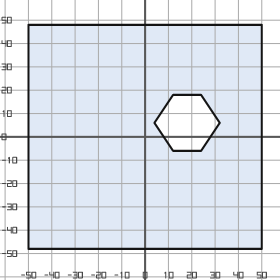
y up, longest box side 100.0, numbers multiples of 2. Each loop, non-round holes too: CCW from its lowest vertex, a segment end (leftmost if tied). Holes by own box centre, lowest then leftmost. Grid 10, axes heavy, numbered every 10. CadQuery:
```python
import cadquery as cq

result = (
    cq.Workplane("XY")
    .moveTo(-50.0, -48.0)
    .lineTo(50.0, -48.0)
    .lineTo(50.0, 48.0)
    .lineTo(-50.0, 48.0)
    .close()
    .moveTo(12.0, -6.0)
    .lineTo(24.0, -6.0)
    .lineTo(32.0, 6.0)
    .lineTo(24.0, 18.0)
    .lineTo(12.0, 18.0)
    .lineTo(4.0, 6.0)
    .close()
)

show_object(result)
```